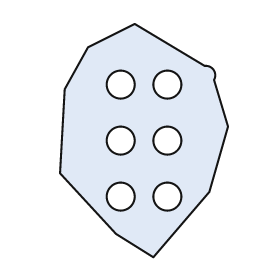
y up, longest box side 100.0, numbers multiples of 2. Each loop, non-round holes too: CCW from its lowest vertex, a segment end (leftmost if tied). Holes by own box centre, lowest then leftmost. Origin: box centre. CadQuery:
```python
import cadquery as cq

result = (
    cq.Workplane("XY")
    .moveTo(4.0, -50.0)
    .lineTo(28.0, -22.0)
    .lineTo(36.0, 6.0)
    .lineTo(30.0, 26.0)
    .threePointArc((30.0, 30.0), (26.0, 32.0))
    .lineTo(-4.0, 50.0)
    .lineTo(-24.0, 40.0)
    .lineTo(-34.0, 22.0)
    .lineTo(-36.0, -14.0)
    .lineTo(-12.0, -40.0)
    .close()
    .moveTo(-10.0, -24.0)
    .circle(6.0)
    .moveTo(10.0, -24.0)
    .circle(6.0)
    .moveTo(-10.0, 0.0)
    .circle(6.0)
    .moveTo(10.0, 0.0)
    .circle(6.0)
    .moveTo(-10.0, 24.0)
    .circle(6.0)
    .moveTo(10.0, 24.0)
    .circle(6.0)
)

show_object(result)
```